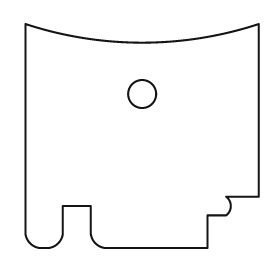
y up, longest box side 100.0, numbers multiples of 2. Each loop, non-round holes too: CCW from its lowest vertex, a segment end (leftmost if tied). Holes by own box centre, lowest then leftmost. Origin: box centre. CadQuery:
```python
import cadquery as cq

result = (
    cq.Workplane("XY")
    .moveTo(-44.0, -48.0)
    .lineTo(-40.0, -48.0)
    .threePointArc((-36.0, -46.0), (-34.0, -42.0))
    .lineTo(-34.0, -30.0)
    .lineTo(-22.0, -30.0)
    .lineTo(-22.0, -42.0)
    .threePointArc((-20.0, -46.0), (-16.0, -48.0))
    .lineTo(28.0, -48.0)
    .lineTo(28.0, -34.0)
    .lineTo(36.0, -34.0)
    .threePointArc((38.0, -30.0), (36.0, -26.0))
    .lineTo(50.0, -26.0)
    .lineTo(50.0, 48.0)
    .threePointArc((0.0, 40.0), (-50.0, 48.0))
    .lineTo(-50.0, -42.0)
    .threePointArc((-48.0, -46.0), (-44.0, -48.0))
    .close()
    .moveTo(0.0, 18.0)
    .circle(6.0)
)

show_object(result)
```